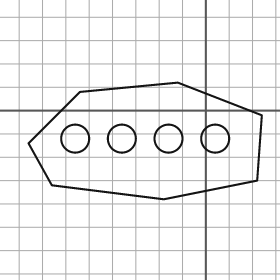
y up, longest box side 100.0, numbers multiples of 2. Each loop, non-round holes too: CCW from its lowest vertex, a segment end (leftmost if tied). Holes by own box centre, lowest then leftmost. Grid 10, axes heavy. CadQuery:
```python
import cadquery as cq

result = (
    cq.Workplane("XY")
    .moveTo(-18.0, -38.0)
    .lineTo(22.0, -30.0)
    .lineTo(24.0, -2.0)
    .lineTo(-12.0, 12.0)
    .lineTo(-54.0, 8.0)
    .lineTo(-76.0, -14.0)
    .lineTo(-66.0, -32.0)
    .close()
    .moveTo(-56.0, -12.0)
    .circle(6.0)
    .moveTo(-36.0, -12.0)
    .circle(6.0)
    .moveTo(-16.0, -12.0)
    .circle(6.0)
    .moveTo(4.0, -12.0)
    .circle(6.0)
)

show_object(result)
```